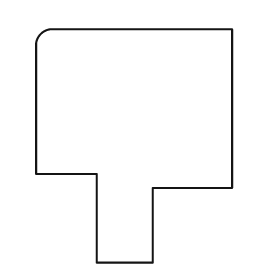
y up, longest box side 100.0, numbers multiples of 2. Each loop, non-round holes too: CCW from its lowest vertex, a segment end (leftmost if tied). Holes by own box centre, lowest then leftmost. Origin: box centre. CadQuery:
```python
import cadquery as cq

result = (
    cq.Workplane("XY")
    .moveTo(-16.0, -50.0)
    .lineTo(8.0, -50.0)
    .lineTo(8.0, -18.0)
    .lineTo(42.0, -18.0)
    .lineTo(42.0, 50.0)
    .lineTo(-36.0, 50.0)
    .threePointArc((-40.0, 48.0), (-42.0, 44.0))
    .lineTo(-42.0, -12.0)
    .lineTo(-16.0, -12.0)
    .close()
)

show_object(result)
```